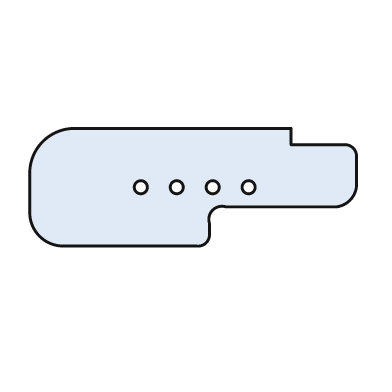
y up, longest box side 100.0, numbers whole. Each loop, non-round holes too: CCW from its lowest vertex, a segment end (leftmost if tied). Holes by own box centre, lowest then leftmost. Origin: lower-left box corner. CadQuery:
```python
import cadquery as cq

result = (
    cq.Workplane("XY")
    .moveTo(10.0, 0.0)
    .lineTo(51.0, 0.0)
    .threePointArc((54.0, 1.0), (55.0, 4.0))
    .lineTo(55.0, 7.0)
    .threePointArc((56.0, 11.0), (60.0, 12.0))
    .lineTo(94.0, 12.0)
    .threePointArc((98.0, 14.0), (100.0, 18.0))
    .lineTo(100.0, 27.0)
    .threePointArc((99.0, 30.0), (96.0, 31.0))
    .lineTo(80.0, 31.0)
    .lineTo(80.0, 36.0)
    .lineTo(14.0, 36.0)
    .threePointArc((4.0, 32.0), (0.0, 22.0))
    .lineTo(0.0, 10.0)
    .threePointArc((3.0, 3.0), (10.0, 0.0))
    .close()
    .moveTo(34.0, 18.0)
    .circle(2.0)
    .moveTo(45.0, 18.0)
    .circle(2.0)
    .moveTo(56.0, 18.0)
    .circle(2.0)
    .moveTo(67.0, 18.0)
    .circle(2.0)
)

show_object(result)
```